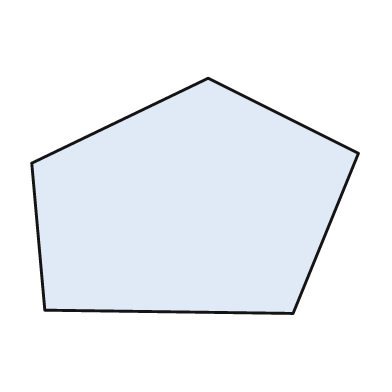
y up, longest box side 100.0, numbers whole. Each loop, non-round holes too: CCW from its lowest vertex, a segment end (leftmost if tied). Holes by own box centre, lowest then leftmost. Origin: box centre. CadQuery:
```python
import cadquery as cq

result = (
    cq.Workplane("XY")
    .moveTo(30.0, -36.0)
    .lineTo(50.0, 13.0)
    .lineTo(4.0, 36.0)
    .lineTo(-50.0, 10.0)
    .lineTo(-46.0, -35.0)
    .close()
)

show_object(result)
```